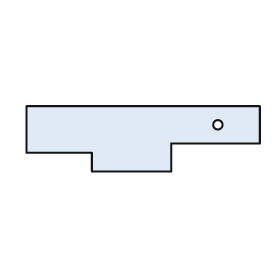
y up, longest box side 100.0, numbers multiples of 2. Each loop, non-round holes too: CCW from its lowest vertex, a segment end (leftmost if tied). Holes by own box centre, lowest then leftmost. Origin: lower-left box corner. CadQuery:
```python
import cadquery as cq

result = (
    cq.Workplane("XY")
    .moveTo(28.0, 0.0)
    .lineTo(62.0, 0.0)
    .lineTo(62.0, 12.0)
    .lineTo(100.0, 12.0)
    .lineTo(100.0, 28.0)
    .lineTo(0.0, 28.0)
    .lineTo(0.0, 8.0)
    .lineTo(28.0, 8.0)
    .close()
    .moveTo(82.0, 20.0)
    .circle(2.0)
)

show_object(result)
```